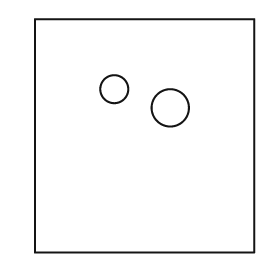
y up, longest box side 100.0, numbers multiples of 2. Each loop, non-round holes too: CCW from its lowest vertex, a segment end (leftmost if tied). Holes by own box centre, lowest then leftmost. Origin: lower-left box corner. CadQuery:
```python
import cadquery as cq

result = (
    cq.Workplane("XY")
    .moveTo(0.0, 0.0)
    .lineTo(94.0, 0.0)
    .lineTo(94.0, 100.0)
    .lineTo(0.0, 100.0)
    .close()
    .moveTo(58.0, 62.0)
    .circle(8.0)
    .moveTo(34.0, 70.0)
    .circle(6.0)
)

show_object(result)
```